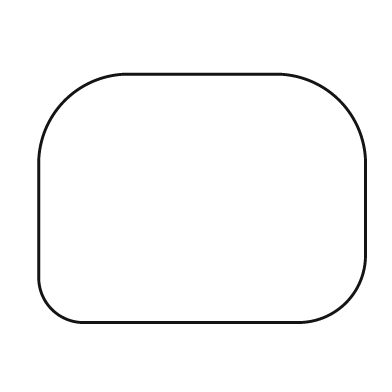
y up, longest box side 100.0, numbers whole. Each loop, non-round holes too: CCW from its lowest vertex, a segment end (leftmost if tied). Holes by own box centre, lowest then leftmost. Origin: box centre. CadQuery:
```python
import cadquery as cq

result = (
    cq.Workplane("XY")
    .moveTo(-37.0, -38.0)
    .lineTo(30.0, -38.0)
    .threePointArc((44.0, -32.0), (50.0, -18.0))
    .lineTo(50.0, 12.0)
    .threePointArc((42.0, 30.0), (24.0, 38.0))
    .lineTo(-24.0, 38.0)
    .threePointArc((-42.0, 30.0), (-50.0, 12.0))
    .lineTo(-50.0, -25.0)
    .threePointArc((-46.0, -34.0), (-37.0, -38.0))
    .close()
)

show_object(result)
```